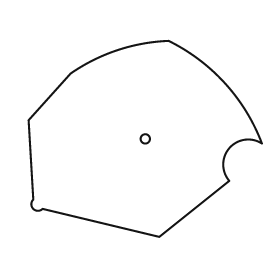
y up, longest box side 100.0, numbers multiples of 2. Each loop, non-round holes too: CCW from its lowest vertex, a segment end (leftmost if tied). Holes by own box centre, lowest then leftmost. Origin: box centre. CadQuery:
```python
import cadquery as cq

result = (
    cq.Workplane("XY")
    .moveTo(6.0, -42.0)
    .lineTo(36.0, -18.0)
    .threePointArc((36.0, -4.0), (50.0, -2.0))
    .threePointArc((34.0, 24.0), (10.0, 42.0))
    .threePointArc((-12.0, 38.0), (-32.0, 28.0))
    .lineTo(-50.0, 8.0)
    .lineTo(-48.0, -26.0)
    .threePointArc((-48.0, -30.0), (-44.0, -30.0))
    .close()
    .moveTo(0.0, 0.0)
    .circle(2.0)
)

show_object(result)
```